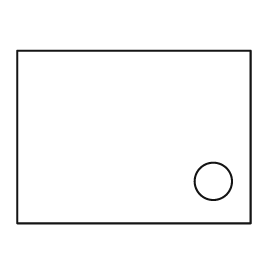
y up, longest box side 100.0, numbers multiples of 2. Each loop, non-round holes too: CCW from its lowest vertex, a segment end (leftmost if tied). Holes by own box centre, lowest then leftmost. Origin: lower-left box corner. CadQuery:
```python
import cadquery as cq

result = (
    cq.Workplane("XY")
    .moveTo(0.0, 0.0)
    .lineTo(100.0, 0.0)
    .lineTo(100.0, 74.0)
    .lineTo(0.0, 74.0)
    .close()
    .moveTo(84.0, 18.0)
    .circle(8.0)
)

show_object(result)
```